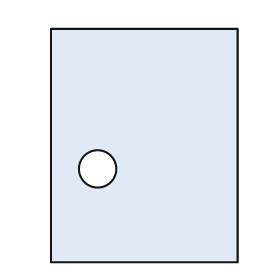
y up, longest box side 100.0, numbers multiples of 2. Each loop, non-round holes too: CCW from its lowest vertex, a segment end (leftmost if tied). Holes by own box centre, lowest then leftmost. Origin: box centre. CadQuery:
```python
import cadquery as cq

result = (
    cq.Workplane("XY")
    .moveTo(-40.0, -50.0)
    .lineTo(40.0, -50.0)
    .lineTo(40.0, 50.0)
    .lineTo(-40.0, 50.0)
    .close()
    .moveTo(-20.0, -10.0)
    .circle(8.0)
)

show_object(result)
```